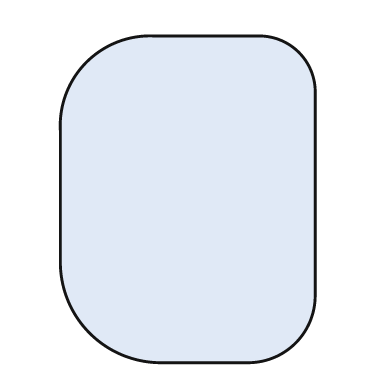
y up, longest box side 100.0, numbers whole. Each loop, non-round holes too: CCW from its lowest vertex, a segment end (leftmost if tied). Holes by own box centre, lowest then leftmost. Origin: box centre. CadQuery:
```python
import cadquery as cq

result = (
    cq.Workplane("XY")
    .moveTo(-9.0, -50.0)
    .lineTo(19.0, -50.0)
    .threePointArc((33.0, -44.0), (39.0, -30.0))
    .lineTo(39.0, 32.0)
    .threePointArc((34.0, 45.0), (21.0, 50.0))
    .lineTo(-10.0, 50.0)
    .threePointArc((-31.0, 42.0), (-39.0, 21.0))
    .lineTo(-39.0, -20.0)
    .threePointArc((-30.0, -41.0), (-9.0, -50.0))
    .close()
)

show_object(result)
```